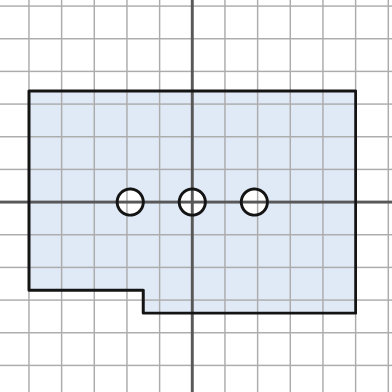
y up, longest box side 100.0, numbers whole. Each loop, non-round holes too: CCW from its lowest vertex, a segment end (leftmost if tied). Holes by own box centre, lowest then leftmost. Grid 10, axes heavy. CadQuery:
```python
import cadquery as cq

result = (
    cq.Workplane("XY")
    .moveTo(-15.0, -34.0)
    .lineTo(50.0, -34.0)
    .lineTo(50.0, 34.0)
    .lineTo(-50.0, 34.0)
    .lineTo(-50.0, -27.0)
    .lineTo(-15.0, -27.0)
    .close()
    .moveTo(-19.0, 0.0)
    .circle(4.0)
    .moveTo(0.0, 0.0)
    .circle(4.0)
    .moveTo(19.0, 0.0)
    .circle(4.0)
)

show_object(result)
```